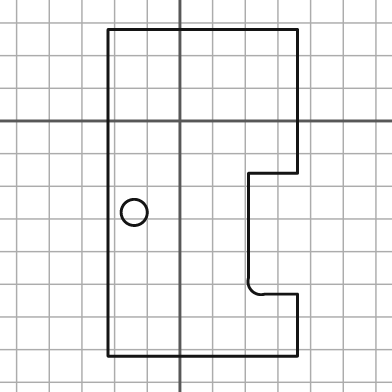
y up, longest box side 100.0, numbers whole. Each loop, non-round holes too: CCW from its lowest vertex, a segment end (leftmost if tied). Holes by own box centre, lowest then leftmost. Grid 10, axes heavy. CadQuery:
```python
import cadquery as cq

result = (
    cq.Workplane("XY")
    .moveTo(-22.0, -72.0)
    .lineTo(36.0, -72.0)
    .lineTo(36.0, -53.0)
    .lineTo(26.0, -53.0)
    .threePointArc((22.0, -52.0), (21.0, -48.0))
    .lineTo(21.0, -16.0)
    .lineTo(36.0, -16.0)
    .lineTo(36.0, 28.0)
    .lineTo(-22.0, 28.0)
    .close()
    .moveTo(-14.0, -28.0)
    .circle(4.0)
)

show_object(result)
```